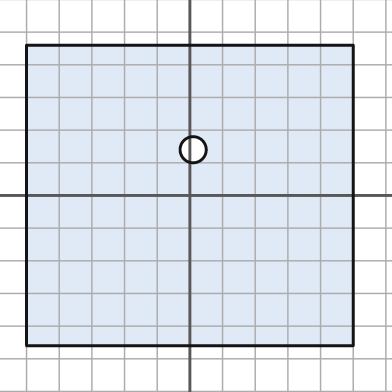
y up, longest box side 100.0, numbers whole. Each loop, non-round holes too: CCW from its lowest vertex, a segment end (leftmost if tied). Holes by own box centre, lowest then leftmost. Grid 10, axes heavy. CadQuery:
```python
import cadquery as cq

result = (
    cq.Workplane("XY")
    .moveTo(-50.0, -46.0)
    .lineTo(50.0, -46.0)
    .lineTo(50.0, 46.0)
    .lineTo(-50.0, 46.0)
    .close()
    .moveTo(1.0, 14.0)
    .circle(4.0)
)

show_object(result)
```